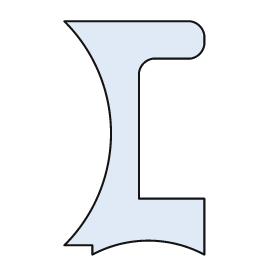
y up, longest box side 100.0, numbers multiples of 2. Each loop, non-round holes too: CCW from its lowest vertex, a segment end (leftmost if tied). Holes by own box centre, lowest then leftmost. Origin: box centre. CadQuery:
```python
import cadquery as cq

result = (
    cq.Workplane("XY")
    .moveTo(-18.0, -50.0)
    .threePointArc((6.0, -44.0), (30.0, -50.0))
    .lineTo(30.0, -26.0)
    .lineTo(2.0, -26.0)
    .lineTo(2.0, 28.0)
    .threePointArc((4.0, 32.0), (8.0, 34.0))
    .lineTo(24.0, 34.0)
    .threePointArc((28.0, 36.0), (30.0, 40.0))
    .lineTo(30.0, 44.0)
    .threePointArc((28.0, 48.0), (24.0, 50.0))
    .lineTo(-30.0, 50.0)
    .threePointArc((-10.0, 2.0), (-30.0, -46.0))
    .lineTo(-18.0, -46.0)
    .close()
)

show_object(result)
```